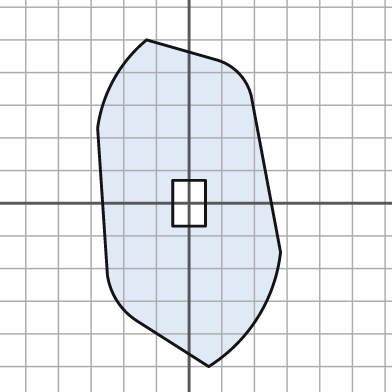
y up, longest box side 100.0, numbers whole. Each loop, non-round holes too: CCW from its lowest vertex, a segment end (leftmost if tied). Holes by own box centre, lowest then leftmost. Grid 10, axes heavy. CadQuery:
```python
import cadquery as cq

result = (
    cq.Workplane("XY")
    .moveTo(6.0, -50.0)
    .threePointArc((21.0, -35.0), (28.0, -15.0))
    .lineTo(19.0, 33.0)
    .threePointArc((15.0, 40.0), (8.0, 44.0))
    .lineTo(-13.0, 50.0)
    .threePointArc((-23.0, 38.0), (-28.0, 23.0))
    .lineTo(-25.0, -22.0)
    .threePointArc((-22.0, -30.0), (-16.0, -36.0))
    .close()
    .moveTo(-5.0, -7.0)
    .lineTo(5.0, -7.0)
    .lineTo(5.0, 7.0)
    .lineTo(-5.0, 7.0)
    .close()
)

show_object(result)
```